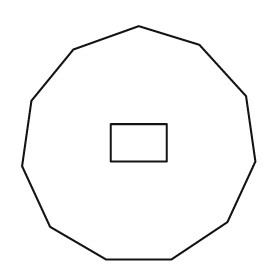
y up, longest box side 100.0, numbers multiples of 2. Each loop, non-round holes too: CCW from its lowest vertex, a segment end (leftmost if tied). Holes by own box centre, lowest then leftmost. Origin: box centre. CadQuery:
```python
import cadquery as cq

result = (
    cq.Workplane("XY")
    .moveTo(-14.0, -50.0)
    .lineTo(14.0, -50.0)
    .lineTo(38.0, -34.0)
    .lineTo(50.0, -8.0)
    .lineTo(46.0, 20.0)
    .lineTo(26.0, 42.0)
    .lineTo(0.0, 50.0)
    .lineTo(-28.0, 40.0)
    .lineTo(-46.0, 18.0)
    .lineTo(-50.0, -10.0)
    .lineTo(-38.0, -36.0)
    .close()
    .moveTo(-12.0, -8.0)
    .lineTo(12.0, -8.0)
    .lineTo(12.0, 8.0)
    .lineTo(-12.0, 8.0)
    .close()
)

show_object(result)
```